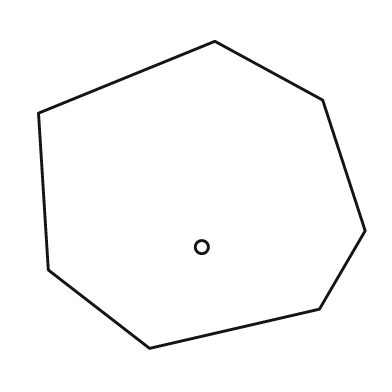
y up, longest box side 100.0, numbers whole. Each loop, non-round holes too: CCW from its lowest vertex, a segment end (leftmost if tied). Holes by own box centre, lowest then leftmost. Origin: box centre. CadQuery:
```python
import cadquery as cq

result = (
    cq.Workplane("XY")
    .moveTo(-16.0, -47.0)
    .lineTo(36.0, -35.0)
    .lineTo(50.0, -11.0)
    .lineTo(37.0, 29.0)
    .lineTo(4.0, 47.0)
    .lineTo(-50.0, 25.0)
    .lineTo(-47.0, -23.0)
    .close()
    .moveTo(0.0, -16.0)
    .circle(2.0)
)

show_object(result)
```